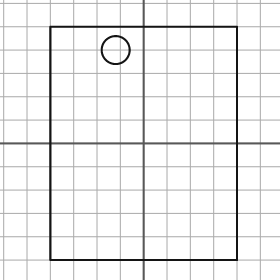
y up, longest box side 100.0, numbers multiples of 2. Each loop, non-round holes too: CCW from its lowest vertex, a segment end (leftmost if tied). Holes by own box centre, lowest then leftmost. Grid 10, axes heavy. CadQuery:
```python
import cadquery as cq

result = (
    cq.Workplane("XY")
    .moveTo(-40.0, -50.0)
    .lineTo(40.0, -50.0)
    .lineTo(40.0, 50.0)
    .lineTo(-40.0, 50.0)
    .close()
    .moveTo(-12.0, 40.0)
    .circle(6.0)
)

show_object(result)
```